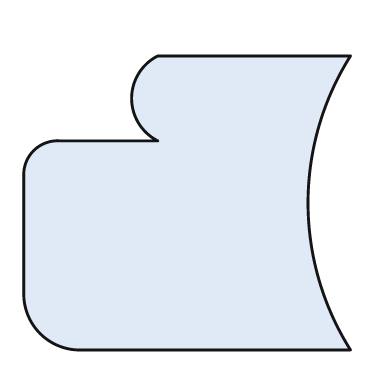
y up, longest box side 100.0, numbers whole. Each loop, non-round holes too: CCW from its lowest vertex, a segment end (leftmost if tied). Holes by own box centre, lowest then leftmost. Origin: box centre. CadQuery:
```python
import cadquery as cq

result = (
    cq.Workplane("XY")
    .moveTo(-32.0, -45.0)
    .lineTo(50.0, -45.0)
    .threePointArc((37.0, 0.0), (50.0, 45.0))
    .lineTo(-9.0, 45.0)
    .threePointArc((-17.0, 32.0), (-9.0, 19.0))
    .lineTo(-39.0, 19.0)
    .threePointArc((-47.0, 16.0), (-50.0, 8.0))
    .lineTo(-50.0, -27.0)
    .threePointArc((-45.0, -40.0), (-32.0, -45.0))
    .close()
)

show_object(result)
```